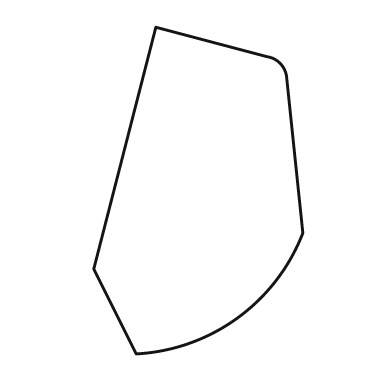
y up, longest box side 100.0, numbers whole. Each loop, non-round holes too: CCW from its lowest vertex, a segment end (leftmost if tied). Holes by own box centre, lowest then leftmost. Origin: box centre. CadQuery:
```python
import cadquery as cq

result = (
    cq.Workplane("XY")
    .moveTo(-19.0, -50.0)
    .threePointArc((12.0, -39.0), (32.0, -13.0))
    .lineTo(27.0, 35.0)
    .threePointArc((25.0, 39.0), (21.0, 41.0))
    .lineTo(-13.0, 50.0)
    .lineTo(-32.0, -24.0)
    .close()
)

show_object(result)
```